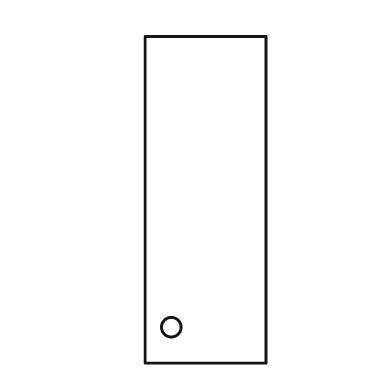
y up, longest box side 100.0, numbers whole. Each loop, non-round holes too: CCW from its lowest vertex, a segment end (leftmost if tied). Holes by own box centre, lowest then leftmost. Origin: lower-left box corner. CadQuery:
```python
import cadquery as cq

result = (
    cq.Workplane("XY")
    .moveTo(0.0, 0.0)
    .lineTo(37.0, 0.0)
    .lineTo(37.0, 100.0)
    .lineTo(0.0, 100.0)
    .close()
    .moveTo(8.0, 11.0)
    .circle(3.0)
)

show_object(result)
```